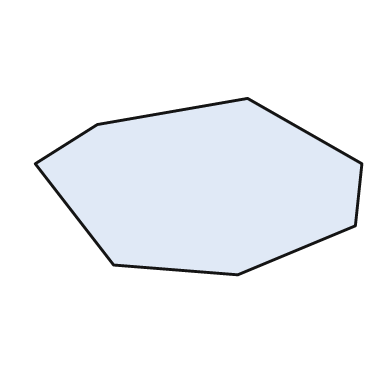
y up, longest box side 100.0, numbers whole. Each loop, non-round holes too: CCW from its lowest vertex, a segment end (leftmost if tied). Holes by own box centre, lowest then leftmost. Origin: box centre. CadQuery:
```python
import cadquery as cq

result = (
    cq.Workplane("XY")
    .moveTo(12.0, -27.0)
    .lineTo(48.0, -12.0)
    .lineTo(50.0, 7.0)
    .lineTo(15.0, 27.0)
    .lineTo(-31.0, 19.0)
    .lineTo(-50.0, 7.0)
    .lineTo(-26.0, -24.0)
    .close()
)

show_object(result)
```